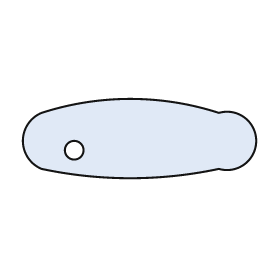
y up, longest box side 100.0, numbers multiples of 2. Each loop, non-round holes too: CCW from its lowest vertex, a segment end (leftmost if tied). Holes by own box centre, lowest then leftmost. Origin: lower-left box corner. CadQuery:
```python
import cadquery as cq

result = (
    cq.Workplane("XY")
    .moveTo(8.0, 4.0)
    .threePointArc((46.0, 0.0), (84.0, 4.0))
    .threePointArc((100.0, 16.0), (84.0, 28.0))
    .threePointArc((46.0, 34.0), (8.0, 28.0))
    .threePointArc((0.0, 16.0), (8.0, 4.0))
    .close()
    .moveTo(22.0, 12.0)
    .circle(4.0)
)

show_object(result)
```